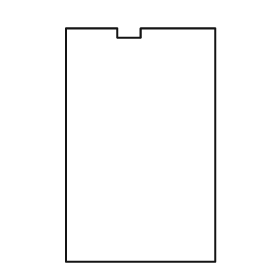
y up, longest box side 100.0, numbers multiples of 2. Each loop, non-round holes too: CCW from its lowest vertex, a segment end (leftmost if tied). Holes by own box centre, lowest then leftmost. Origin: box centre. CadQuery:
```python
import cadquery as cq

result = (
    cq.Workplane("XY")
    .moveTo(-32.0, -50.0)
    .lineTo(32.0, -50.0)
    .lineTo(32.0, 50.0)
    .lineTo(0.0, 50.0)
    .lineTo(0.0, 46.0)
    .lineTo(-10.0, 46.0)
    .lineTo(-10.0, 50.0)
    .lineTo(-32.0, 50.0)
    .close()
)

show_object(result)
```